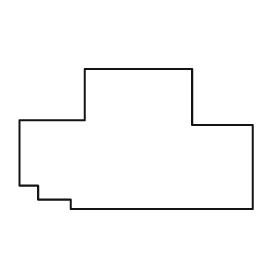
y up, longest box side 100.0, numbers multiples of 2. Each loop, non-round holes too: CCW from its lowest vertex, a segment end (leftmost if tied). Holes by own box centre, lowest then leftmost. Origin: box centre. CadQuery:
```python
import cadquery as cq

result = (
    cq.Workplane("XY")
    .moveTo(-28.0, -30.0)
    .lineTo(50.0, -30.0)
    .lineTo(50.0, 6.0)
    .lineTo(24.0, 6.0)
    .lineTo(24.0, 30.0)
    .lineTo(-22.0, 30.0)
    .lineTo(-22.0, 8.0)
    .lineTo(-50.0, 8.0)
    .lineTo(-50.0, -20.0)
    .lineTo(-42.0, -20.0)
    .lineTo(-42.0, -26.0)
    .lineTo(-28.0, -26.0)
    .close()
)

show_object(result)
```